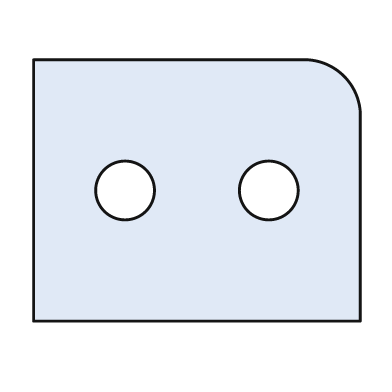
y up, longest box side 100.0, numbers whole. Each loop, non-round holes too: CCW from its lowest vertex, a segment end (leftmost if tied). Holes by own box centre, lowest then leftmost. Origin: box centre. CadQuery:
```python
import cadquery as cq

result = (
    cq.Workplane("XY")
    .moveTo(-50.0, -40.0)
    .lineTo(50.0, -40.0)
    .lineTo(50.0, 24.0)
    .threePointArc((45.0, 35.0), (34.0, 40.0))
    .lineTo(-50.0, 40.0)
    .close()
    .moveTo(-22.0, 0.0)
    .circle(9.0)
    .moveTo(22.0, 0.0)
    .circle(9.0)
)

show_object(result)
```